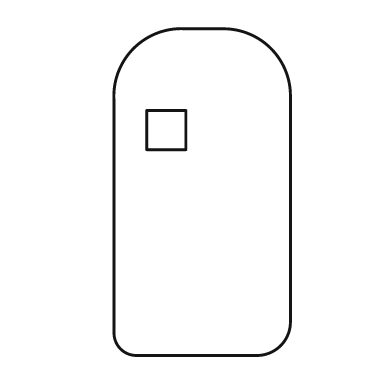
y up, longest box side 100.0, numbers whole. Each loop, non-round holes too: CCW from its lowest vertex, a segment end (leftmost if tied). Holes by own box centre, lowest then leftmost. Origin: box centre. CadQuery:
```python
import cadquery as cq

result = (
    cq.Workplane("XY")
    .moveTo(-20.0, -50.0)
    .lineTo(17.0, -50.0)
    .threePointArc((24.0, -47.0), (27.0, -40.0))
    .lineTo(27.0, 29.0)
    .threePointArc((21.0, 44.0), (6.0, 50.0))
    .lineTo(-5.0, 50.0)
    .threePointArc((-21.0, 44.0), (-27.0, 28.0))
    .lineTo(-27.0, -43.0)
    .threePointArc((-25.0, -48.0), (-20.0, -50.0))
    .close()
    .moveTo(-17.0, 13.0)
    .lineTo(-5.0, 13.0)
    .lineTo(-5.0, 25.0)
    .lineTo(-17.0, 25.0)
    .close()
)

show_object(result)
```